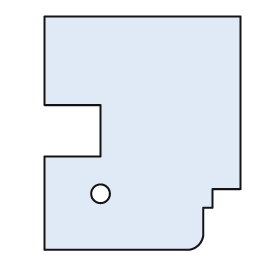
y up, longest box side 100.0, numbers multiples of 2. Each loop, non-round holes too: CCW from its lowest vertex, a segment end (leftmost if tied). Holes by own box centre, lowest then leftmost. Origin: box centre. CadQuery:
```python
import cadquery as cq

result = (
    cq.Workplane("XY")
    .moveTo(-42.0, -50.0)
    .lineTo(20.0, -50.0)
    .threePointArc((24.0, -48.0), (26.0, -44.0))
    .lineTo(26.0, -32.0)
    .lineTo(30.0, -32.0)
    .lineTo(30.0, -24.0)
    .lineTo(42.0, -24.0)
    .lineTo(42.0, 50.0)
    .lineTo(-42.0, 50.0)
    .lineTo(-42.0, 12.0)
    .lineTo(-18.0, 12.0)
    .lineTo(-18.0, -10.0)
    .lineTo(-42.0, -10.0)
    .close()
    .moveTo(-18.0, -26.0)
    .circle(4.0)
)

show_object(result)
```